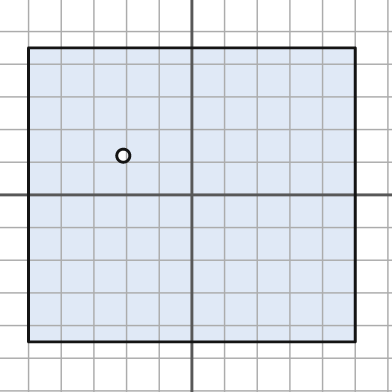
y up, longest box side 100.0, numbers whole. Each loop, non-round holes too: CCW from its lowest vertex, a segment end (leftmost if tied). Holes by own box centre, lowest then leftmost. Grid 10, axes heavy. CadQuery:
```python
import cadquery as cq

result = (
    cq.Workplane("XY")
    .moveTo(-50.0, -45.0)
    .lineTo(50.0, -45.0)
    .lineTo(50.0, 45.0)
    .lineTo(-50.0, 45.0)
    .close()
    .moveTo(-21.0, 12.0)
    .circle(2.0)
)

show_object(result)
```